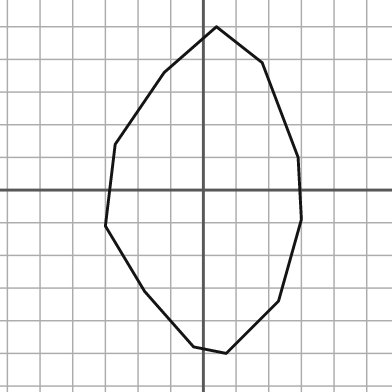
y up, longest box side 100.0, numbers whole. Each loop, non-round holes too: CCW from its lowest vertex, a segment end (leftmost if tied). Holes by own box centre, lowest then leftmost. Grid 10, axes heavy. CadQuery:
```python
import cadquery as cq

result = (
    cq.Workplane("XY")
    .moveTo(7.0, -50.0)
    .lineTo(23.0, -34.0)
    .lineTo(30.0, -9.0)
    .lineTo(29.0, 10.0)
    .lineTo(18.0, 39.0)
    .lineTo(4.0, 50.0)
    .lineTo(-12.0, 36.0)
    .lineTo(-27.0, 14.0)
    .lineTo(-30.0, -11.0)
    .lineTo(-18.0, -31.0)
    .lineTo(-3.0, -48.0)
    .close()
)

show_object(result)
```